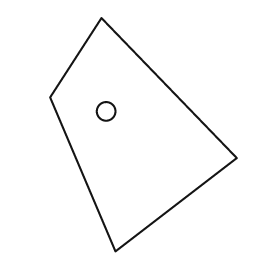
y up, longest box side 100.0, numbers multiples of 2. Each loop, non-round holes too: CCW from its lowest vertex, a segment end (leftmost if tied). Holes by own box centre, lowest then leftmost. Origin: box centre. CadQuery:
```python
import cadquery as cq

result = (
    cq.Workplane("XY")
    .moveTo(-12.0, -50.0)
    .lineTo(40.0, -10.0)
    .lineTo(-18.0, 50.0)
    .lineTo(-40.0, 16.0)
    .close()
    .moveTo(-16.0, 10.0)
    .circle(4.0)
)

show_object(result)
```